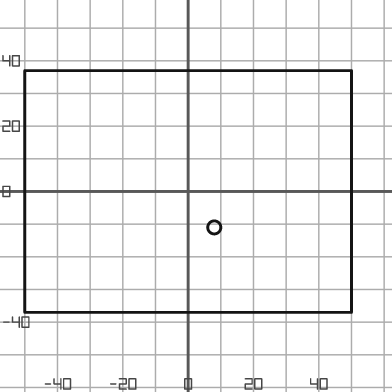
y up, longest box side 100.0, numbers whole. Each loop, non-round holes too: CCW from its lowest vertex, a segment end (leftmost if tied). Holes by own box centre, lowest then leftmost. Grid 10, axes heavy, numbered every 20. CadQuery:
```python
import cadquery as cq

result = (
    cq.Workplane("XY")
    .moveTo(-50.0, -37.0)
    .lineTo(50.0, -37.0)
    .lineTo(50.0, 37.0)
    .lineTo(-50.0, 37.0)
    .close()
    .moveTo(8.0, -11.0)
    .circle(2.0)
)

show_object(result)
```